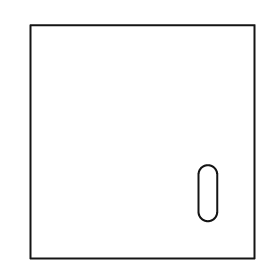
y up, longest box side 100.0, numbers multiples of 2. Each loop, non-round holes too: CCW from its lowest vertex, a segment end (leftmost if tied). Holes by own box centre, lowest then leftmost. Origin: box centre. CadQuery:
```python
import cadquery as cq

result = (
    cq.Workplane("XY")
    .moveTo(-48.0, -50.0)
    .lineTo(48.0, -50.0)
    .lineTo(48.0, 50.0)
    .lineTo(-48.0, 50.0)
    .close()
    .moveTo(24.0, -30.0)
    .threePointArc((28.0, -34.0), (32.0, -30.0))
    .lineTo(32.0, -14.0)
    .threePointArc((28.0, -10.0), (24.0, -14.0))
    .close()
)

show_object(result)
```